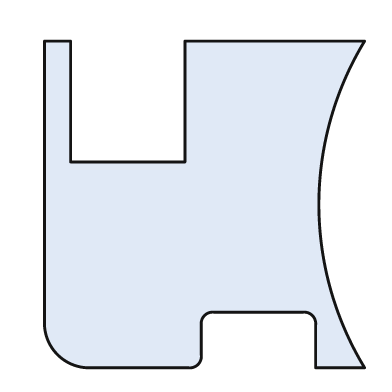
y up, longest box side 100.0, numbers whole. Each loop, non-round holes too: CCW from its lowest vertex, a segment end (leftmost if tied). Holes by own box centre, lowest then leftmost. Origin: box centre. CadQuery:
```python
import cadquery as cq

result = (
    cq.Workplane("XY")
    .moveTo(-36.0, -50.0)
    .lineTo(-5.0, -50.0)
    .threePointArc((-2.0, -49.0), (-1.0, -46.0))
    .lineTo(-1.0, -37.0)
    .threePointArc((0.0, -34.0), (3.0, -33.0))
    .lineTo(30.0, -33.0)
    .threePointArc((33.0, -34.0), (34.0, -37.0))
    .lineTo(34.0, -50.0)
    .lineTo(49.0, -50.0)
    .threePointArc((35.0, 0.0), (49.0, 50.0))
    .lineTo(-6.0, 50.0)
    .lineTo(-6.0, 13.0)
    .lineTo(-41.0, 13.0)
    .lineTo(-41.0, 50.0)
    .lineTo(-49.0, 50.0)
    .lineTo(-49.0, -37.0)
    .threePointArc((-45.0, -46.0), (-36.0, -50.0))
    .close()
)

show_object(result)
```